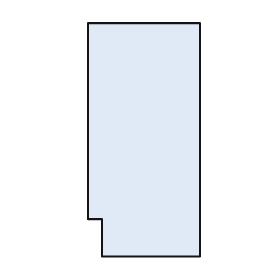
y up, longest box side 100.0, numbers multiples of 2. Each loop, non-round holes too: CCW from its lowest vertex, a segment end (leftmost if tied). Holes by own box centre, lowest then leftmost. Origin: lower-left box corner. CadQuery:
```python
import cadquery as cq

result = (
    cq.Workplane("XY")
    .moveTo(6.0, 0.0)
    .lineTo(48.0, 0.0)
    .lineTo(48.0, 100.0)
    .lineTo(0.0, 100.0)
    .lineTo(0.0, 16.0)
    .lineTo(6.0, 16.0)
    .close()
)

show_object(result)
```